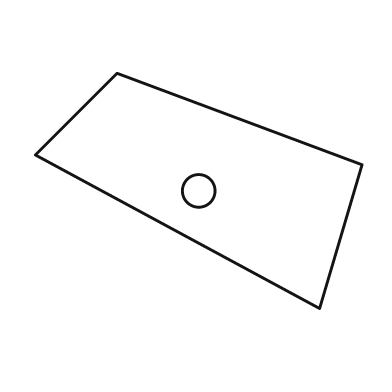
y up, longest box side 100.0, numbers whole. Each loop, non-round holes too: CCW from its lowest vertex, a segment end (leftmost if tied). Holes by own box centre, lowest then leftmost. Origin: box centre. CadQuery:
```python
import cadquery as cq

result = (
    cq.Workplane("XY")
    .moveTo(37.0, -36.0)
    .lineTo(50.0, 8.0)
    .lineTo(-25.0, 36.0)
    .lineTo(-50.0, 11.0)
    .close()
    .moveTo(0.0, 0.0)
    .circle(5.0)
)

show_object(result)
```